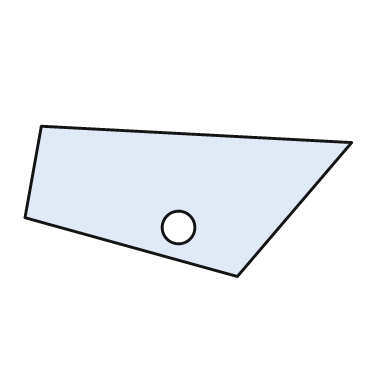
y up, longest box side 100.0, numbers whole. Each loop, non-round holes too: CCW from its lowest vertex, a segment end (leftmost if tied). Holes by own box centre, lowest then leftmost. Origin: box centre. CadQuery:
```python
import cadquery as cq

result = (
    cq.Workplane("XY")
    .moveTo(15.0, -23.0)
    .lineTo(50.0, 18.0)
    .lineTo(-45.0, 23.0)
    .lineTo(-50.0, -5.0)
    .close()
    .moveTo(-3.0, -8.0)
    .circle(5.0)
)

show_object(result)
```